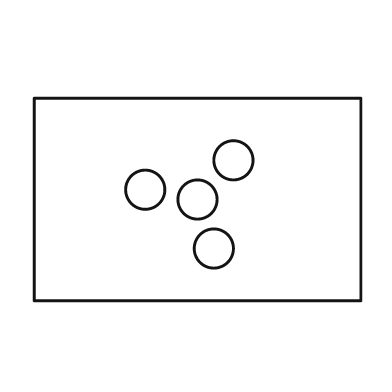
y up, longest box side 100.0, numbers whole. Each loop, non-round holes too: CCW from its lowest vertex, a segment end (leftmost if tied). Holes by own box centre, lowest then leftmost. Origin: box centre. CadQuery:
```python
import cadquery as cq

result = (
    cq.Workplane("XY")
    .moveTo(-50.0, -31.0)
    .lineTo(50.0, -31.0)
    .lineTo(50.0, 31.0)
    .lineTo(-50.0, 31.0)
    .close()
    .moveTo(5.0, -15.0)
    .circle(6.0)
    .moveTo(0.0, 0.0)
    .circle(6.0)
    .moveTo(-16.0, 3.0)
    .circle(6.0)
    .moveTo(11.0, 12.0)
    .circle(6.0)
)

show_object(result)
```